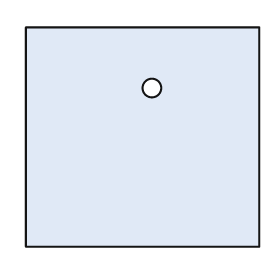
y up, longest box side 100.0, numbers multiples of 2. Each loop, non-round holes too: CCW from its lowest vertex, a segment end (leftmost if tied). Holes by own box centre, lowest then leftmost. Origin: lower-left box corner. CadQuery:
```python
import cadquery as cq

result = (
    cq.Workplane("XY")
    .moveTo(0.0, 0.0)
    .lineTo(100.0, 0.0)
    .lineTo(100.0, 94.0)
    .lineTo(0.0, 94.0)
    .close()
    .moveTo(54.0, 68.0)
    .circle(4.0)
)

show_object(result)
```